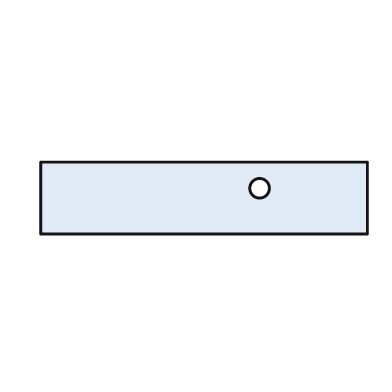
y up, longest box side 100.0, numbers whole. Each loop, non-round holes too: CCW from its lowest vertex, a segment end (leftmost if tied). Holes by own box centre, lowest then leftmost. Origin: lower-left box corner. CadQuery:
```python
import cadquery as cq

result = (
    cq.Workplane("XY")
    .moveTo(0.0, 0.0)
    .lineTo(100.0, 0.0)
    .lineTo(100.0, 22.0)
    .lineTo(0.0, 22.0)
    .close()
    .moveTo(67.0, 14.0)
    .circle(3.0)
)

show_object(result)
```